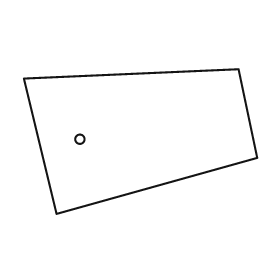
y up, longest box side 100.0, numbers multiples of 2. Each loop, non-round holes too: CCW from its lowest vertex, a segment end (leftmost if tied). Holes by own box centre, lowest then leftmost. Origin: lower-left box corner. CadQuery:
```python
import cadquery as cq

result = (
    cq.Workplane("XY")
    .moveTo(14.0, 0.0)
    .lineTo(100.0, 24.0)
    .lineTo(92.0, 62.0)
    .lineTo(0.0, 58.0)
    .close()
    .moveTo(24.0, 32.0)
    .circle(2.0)
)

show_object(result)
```